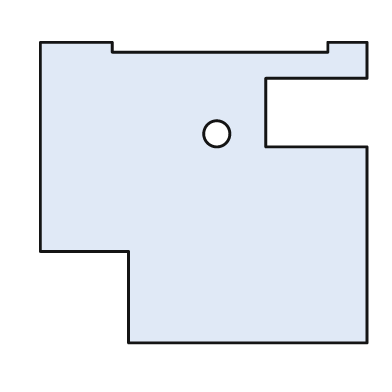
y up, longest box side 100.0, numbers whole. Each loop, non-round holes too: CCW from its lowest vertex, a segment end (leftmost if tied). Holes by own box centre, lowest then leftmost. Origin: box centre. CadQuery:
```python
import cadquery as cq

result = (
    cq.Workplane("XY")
    .moveTo(-23.0, -46.0)
    .lineTo(50.0, -46.0)
    .lineTo(50.0, 14.0)
    .lineTo(19.0, 14.0)
    .lineTo(19.0, 35.0)
    .lineTo(50.0, 35.0)
    .lineTo(50.0, 46.0)
    .lineTo(38.0, 46.0)
    .lineTo(38.0, 43.0)
    .lineTo(-28.0, 43.0)
    .lineTo(-28.0, 46.0)
    .lineTo(-50.0, 46.0)
    .lineTo(-50.0, -18.0)
    .lineTo(-23.0, -18.0)
    .close()
    .moveTo(4.0, 18.0)
    .circle(4.0)
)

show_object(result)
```